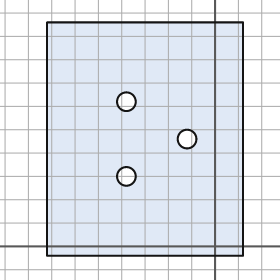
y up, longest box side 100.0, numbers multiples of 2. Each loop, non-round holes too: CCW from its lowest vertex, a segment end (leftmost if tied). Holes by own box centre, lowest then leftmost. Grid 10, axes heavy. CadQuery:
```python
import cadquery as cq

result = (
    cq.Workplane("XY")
    .moveTo(-72.0, -4.0)
    .lineTo(12.0, -4.0)
    .lineTo(12.0, 96.0)
    .lineTo(-72.0, 96.0)
    .close()
    .moveTo(-38.0, 30.0)
    .circle(4.0)
    .moveTo(-12.0, 46.0)
    .circle(4.0)
    .moveTo(-38.0, 62.0)
    .circle(4.0)
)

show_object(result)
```